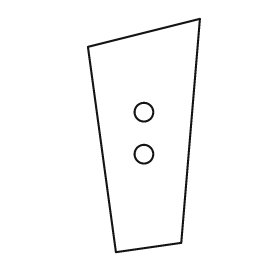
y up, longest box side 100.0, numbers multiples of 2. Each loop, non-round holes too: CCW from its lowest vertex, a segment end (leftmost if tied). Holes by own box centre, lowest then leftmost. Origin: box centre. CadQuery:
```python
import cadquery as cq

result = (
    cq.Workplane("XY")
    .moveTo(-12.0, -50.0)
    .lineTo(16.0, -46.0)
    .lineTo(24.0, 50.0)
    .lineTo(-24.0, 38.0)
    .close()
    .moveTo(0.0, -8.0)
    .circle(4.0)
    .moveTo(0.0, 10.0)
    .circle(4.0)
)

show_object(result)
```